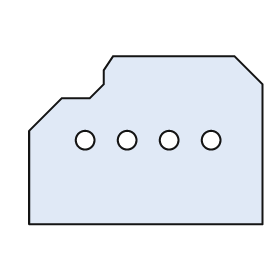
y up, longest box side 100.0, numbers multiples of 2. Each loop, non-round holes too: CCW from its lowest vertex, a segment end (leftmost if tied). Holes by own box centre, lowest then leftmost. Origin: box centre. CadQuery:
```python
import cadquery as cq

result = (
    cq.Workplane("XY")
    .moveTo(-50.0, -36.0)
    .lineTo(50.0, -36.0)
    .lineTo(50.0, 24.0)
    .lineTo(38.0, 36.0)
    .lineTo(-14.0, 36.0)
    .lineTo(-18.0, 30.0)
    .lineTo(-18.0, 24.0)
    .lineTo(-24.0, 18.0)
    .lineTo(-36.0, 18.0)
    .lineTo(-50.0, 4.0)
    .close()
    .moveTo(-26.0, 0.0)
    .circle(4.0)
    .moveTo(-8.0, 0.0)
    .circle(4.0)
    .moveTo(10.0, 0.0)
    .circle(4.0)
    .moveTo(28.0, 0.0)
    .circle(4.0)
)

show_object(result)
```